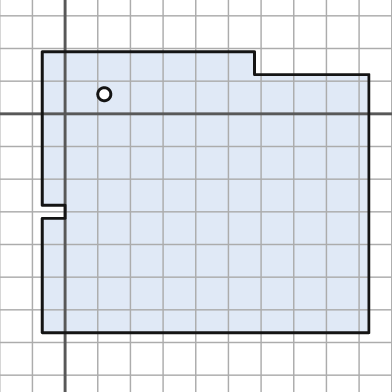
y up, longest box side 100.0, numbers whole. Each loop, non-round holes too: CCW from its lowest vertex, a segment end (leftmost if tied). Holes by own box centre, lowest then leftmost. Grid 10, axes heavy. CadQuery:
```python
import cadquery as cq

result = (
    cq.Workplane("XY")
    .moveTo(-7.0, -67.0)
    .lineTo(93.0, -67.0)
    .lineTo(93.0, 12.0)
    .lineTo(58.0, 12.0)
    .lineTo(58.0, 19.0)
    .lineTo(-7.0, 19.0)
    .lineTo(-7.0, -28.0)
    .lineTo(0.0, -28.0)
    .lineTo(0.0, -32.0)
    .lineTo(-7.0, -32.0)
    .close()
    .moveTo(12.0, 6.0)
    .circle(2.0)
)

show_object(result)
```